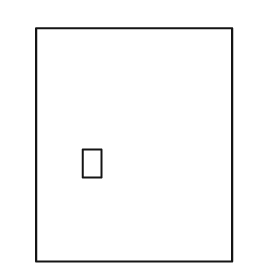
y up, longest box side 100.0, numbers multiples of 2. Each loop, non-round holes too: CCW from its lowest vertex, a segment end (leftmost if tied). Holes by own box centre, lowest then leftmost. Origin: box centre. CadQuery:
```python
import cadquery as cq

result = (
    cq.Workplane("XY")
    .moveTo(-42.0, -50.0)
    .lineTo(42.0, -50.0)
    .lineTo(42.0, 50.0)
    .lineTo(-42.0, 50.0)
    .close()
    .moveTo(-22.0, -14.0)
    .lineTo(-14.0, -14.0)
    .lineTo(-14.0, -2.0)
    .lineTo(-22.0, -2.0)
    .close()
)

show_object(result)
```